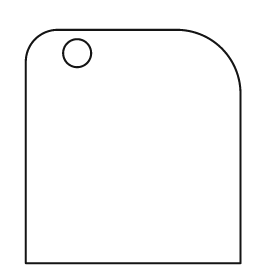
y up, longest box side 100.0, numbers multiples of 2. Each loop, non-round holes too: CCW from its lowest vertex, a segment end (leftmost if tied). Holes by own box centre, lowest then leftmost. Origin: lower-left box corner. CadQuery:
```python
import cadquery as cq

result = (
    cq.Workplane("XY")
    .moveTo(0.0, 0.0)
    .lineTo(92.0, 0.0)
    .lineTo(92.0, 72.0)
    .threePointArc((84.0, 92.0), (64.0, 100.0))
    .lineTo(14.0, 100.0)
    .threePointArc((4.0, 96.0), (0.0, 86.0))
    .close()
    .moveTo(22.0, 90.0)
    .circle(6.0)
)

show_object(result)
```